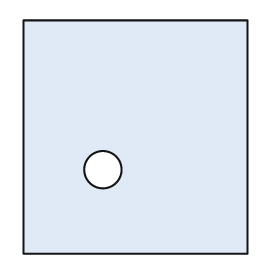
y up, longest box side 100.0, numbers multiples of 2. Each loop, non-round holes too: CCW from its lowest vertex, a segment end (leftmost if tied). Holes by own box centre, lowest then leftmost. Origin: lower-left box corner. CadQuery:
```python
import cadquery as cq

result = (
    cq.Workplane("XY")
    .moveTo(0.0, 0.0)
    .lineTo(96.0, 0.0)
    .lineTo(96.0, 100.0)
    .lineTo(0.0, 100.0)
    .close()
    .moveTo(34.0, 36.0)
    .circle(8.0)
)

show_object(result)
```